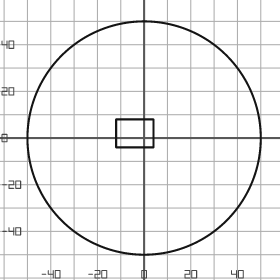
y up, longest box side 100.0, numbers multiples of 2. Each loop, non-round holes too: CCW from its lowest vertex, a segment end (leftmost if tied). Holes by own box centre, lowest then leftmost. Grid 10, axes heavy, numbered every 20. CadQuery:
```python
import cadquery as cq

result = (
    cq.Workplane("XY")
    .moveTo(0.0, 0.0)
    .circle(50.0)
    .moveTo(-12.0, -4.0)
    .lineTo(4.0, -4.0)
    .lineTo(4.0, 8.0)
    .lineTo(-12.0, 8.0)
    .close()
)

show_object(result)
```